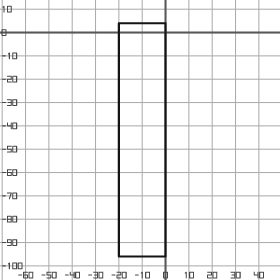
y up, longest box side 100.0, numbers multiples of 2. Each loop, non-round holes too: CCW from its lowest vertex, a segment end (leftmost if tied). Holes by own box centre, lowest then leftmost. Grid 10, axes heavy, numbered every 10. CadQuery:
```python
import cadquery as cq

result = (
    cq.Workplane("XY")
    .moveTo(-20.0, -96.0)
    .lineTo(0.0, -96.0)
    .lineTo(0.0, 4.0)
    .lineTo(-20.0, 4.0)
    .close()
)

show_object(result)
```